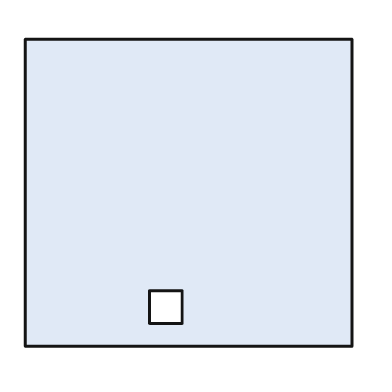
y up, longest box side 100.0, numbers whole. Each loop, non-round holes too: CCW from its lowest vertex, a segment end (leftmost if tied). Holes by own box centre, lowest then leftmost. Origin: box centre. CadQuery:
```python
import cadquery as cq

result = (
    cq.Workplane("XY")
    .moveTo(-50.0, -47.0)
    .lineTo(50.0, -47.0)
    .lineTo(50.0, 47.0)
    .lineTo(-50.0, 47.0)
    .close()
    .moveTo(-12.0, -40.0)
    .lineTo(-2.0, -40.0)
    .lineTo(-2.0, -30.0)
    .lineTo(-12.0, -30.0)
    .close()
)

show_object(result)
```